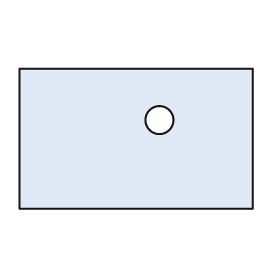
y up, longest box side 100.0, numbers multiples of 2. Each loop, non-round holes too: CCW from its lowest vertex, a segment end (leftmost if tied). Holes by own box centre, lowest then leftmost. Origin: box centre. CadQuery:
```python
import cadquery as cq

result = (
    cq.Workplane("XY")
    .moveTo(-50.0, -30.0)
    .lineTo(50.0, -30.0)
    .lineTo(50.0, 30.0)
    .lineTo(-50.0, 30.0)
    .close()
    .moveTo(10.0, 8.0)
    .circle(6.0)
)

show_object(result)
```